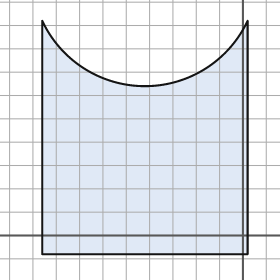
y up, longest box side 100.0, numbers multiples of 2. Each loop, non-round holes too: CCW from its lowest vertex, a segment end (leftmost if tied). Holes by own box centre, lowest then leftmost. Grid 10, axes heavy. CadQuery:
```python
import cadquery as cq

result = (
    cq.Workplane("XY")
    .moveTo(-86.0, -8.0)
    .lineTo(2.0, -8.0)
    .lineTo(2.0, 92.0)
    .threePointArc((-42.0, 64.0), (-86.0, 92.0))
    .close()
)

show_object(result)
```